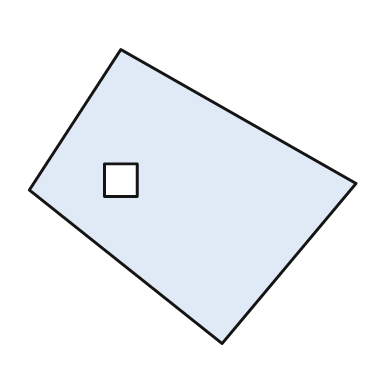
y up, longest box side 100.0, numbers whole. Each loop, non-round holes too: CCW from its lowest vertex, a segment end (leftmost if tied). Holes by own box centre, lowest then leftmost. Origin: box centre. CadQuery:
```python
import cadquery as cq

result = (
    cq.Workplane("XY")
    .moveTo(9.0, -45.0)
    .lineTo(50.0, 4.0)
    .lineTo(-22.0, 45.0)
    .lineTo(-50.0, 2.0)
    .close()
    .moveTo(-27.0, 0.0)
    .lineTo(-17.0, 0.0)
    .lineTo(-17.0, 10.0)
    .lineTo(-27.0, 10.0)
    .close()
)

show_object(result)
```